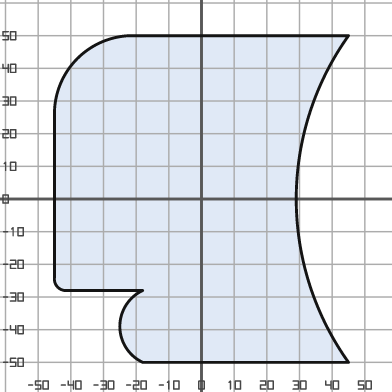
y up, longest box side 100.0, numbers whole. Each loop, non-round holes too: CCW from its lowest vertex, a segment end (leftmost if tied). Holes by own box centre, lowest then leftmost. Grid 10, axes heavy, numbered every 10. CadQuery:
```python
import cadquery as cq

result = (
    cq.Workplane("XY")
    .moveTo(-18.0, -50.0)
    .lineTo(45.0, -50.0)
    .threePointArc((29.0, 0.0), (45.0, 50.0))
    .lineTo(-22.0, 50.0)
    .threePointArc((-38.0, 43.0), (-45.0, 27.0))
    .lineTo(-45.0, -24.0)
    .threePointArc((-44.0, -27.0), (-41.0, -28.0))
    .lineTo(-18.0, -28.0)
    .threePointArc((-25.0, -39.0), (-18.0, -50.0))
    .close()
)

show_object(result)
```